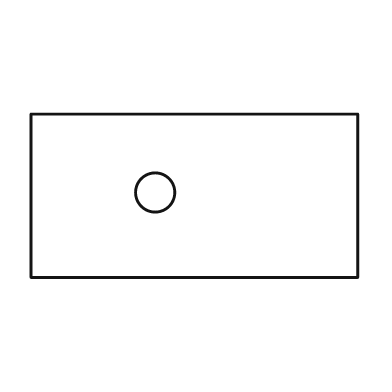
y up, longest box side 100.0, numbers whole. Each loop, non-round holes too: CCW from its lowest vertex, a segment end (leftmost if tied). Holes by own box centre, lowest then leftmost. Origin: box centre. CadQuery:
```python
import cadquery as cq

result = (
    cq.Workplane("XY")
    .moveTo(-50.0, -25.0)
    .lineTo(50.0, -25.0)
    .lineTo(50.0, 25.0)
    .lineTo(-50.0, 25.0)
    .close()
    .moveTo(-12.0, 1.0)
    .circle(6.0)
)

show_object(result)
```